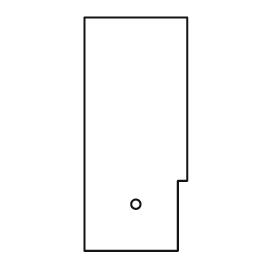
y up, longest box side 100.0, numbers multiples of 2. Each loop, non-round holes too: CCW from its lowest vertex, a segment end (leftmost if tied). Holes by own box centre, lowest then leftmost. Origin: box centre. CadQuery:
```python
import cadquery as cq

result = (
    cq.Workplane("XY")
    .moveTo(-22.0, -50.0)
    .lineTo(18.0, -50.0)
    .lineTo(18.0, -20.0)
    .lineTo(22.0, -20.0)
    .lineTo(22.0, 50.0)
    .lineTo(-22.0, 50.0)
    .close()
    .moveTo(0.0, -30.0)
    .circle(2.0)
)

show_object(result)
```